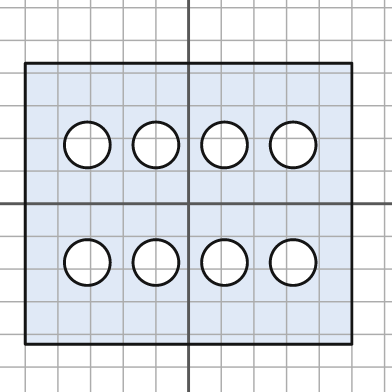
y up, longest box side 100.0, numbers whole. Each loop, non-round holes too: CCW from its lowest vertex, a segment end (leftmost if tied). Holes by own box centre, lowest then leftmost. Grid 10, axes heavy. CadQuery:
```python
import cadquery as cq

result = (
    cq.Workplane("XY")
    .moveTo(-50.0, -43.0)
    .lineTo(50.0, -43.0)
    .lineTo(50.0, 43.0)
    .lineTo(-50.0, 43.0)
    .close()
    .moveTo(-31.0, -18.0)
    .circle(7.0)
    .moveTo(-10.0, -18.0)
    .circle(7.0)
    .moveTo(11.0, -18.0)
    .circle(7.0)
    .moveTo(32.0, -18.0)
    .circle(7.0)
    .moveTo(-31.0, 18.0)
    .circle(7.0)
    .moveTo(-10.0, 18.0)
    .circle(7.0)
    .moveTo(11.0, 18.0)
    .circle(7.0)
    .moveTo(32.0, 18.0)
    .circle(7.0)
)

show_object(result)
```